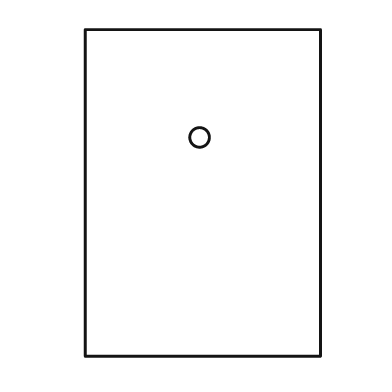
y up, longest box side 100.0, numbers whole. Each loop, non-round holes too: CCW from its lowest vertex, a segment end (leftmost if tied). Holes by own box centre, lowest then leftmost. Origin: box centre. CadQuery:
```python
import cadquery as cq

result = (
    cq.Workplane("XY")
    .moveTo(-36.0, -50.0)
    .lineTo(36.0, -50.0)
    .lineTo(36.0, 50.0)
    .lineTo(-36.0, 50.0)
    .close()
    .moveTo(-1.0, 17.0)
    .circle(3.0)
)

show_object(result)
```